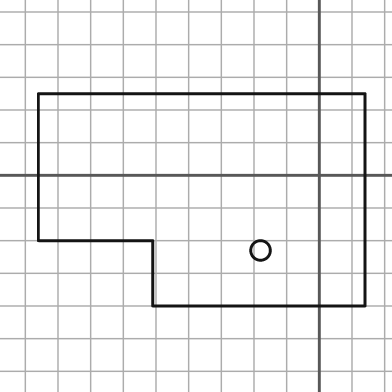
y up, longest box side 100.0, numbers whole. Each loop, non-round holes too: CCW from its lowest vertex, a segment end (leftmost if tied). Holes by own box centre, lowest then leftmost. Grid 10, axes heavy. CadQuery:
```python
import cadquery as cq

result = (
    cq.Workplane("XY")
    .moveTo(-51.0, -40.0)
    .lineTo(14.0, -40.0)
    .lineTo(14.0, 25.0)
    .lineTo(-86.0, 25.0)
    .lineTo(-86.0, -20.0)
    .lineTo(-51.0, -20.0)
    .close()
    .moveTo(-18.0, -23.0)
    .circle(3.0)
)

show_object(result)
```